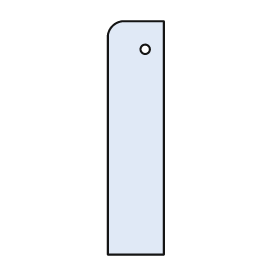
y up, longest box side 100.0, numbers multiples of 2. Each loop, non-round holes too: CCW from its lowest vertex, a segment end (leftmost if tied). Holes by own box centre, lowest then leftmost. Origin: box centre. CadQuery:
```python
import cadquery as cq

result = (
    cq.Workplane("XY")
    .moveTo(-12.0, -50.0)
    .lineTo(12.0, -50.0)
    .lineTo(12.0, 50.0)
    .lineTo(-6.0, 50.0)
    .threePointArc((-10.0, 48.0), (-12.0, 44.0))
    .close()
    .moveTo(4.0, 38.0)
    .circle(2.0)
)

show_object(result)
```